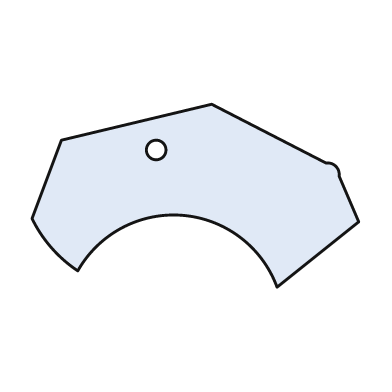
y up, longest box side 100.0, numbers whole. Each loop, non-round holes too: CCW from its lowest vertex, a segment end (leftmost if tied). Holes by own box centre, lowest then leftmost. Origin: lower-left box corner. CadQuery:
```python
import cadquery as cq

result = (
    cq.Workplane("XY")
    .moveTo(75.0, 0.0)
    .lineTo(100.0, 20.0)
    .lineTo(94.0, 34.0)
    .threePointArc((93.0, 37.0), (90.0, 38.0))
    .lineTo(55.0, 56.0)
    .lineTo(9.0, 45.0)
    .lineTo(0.0, 21.0)
    .threePointArc((6.0, 12.0), (14.0, 5.0))
    .threePointArc((46.0, 22.0), (75.0, 0.0))
    .close()
    .moveTo(38.0, 42.0)
    .circle(3.0)
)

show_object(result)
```